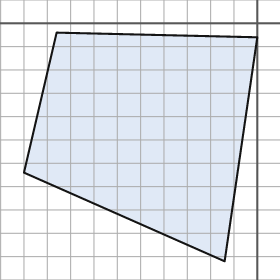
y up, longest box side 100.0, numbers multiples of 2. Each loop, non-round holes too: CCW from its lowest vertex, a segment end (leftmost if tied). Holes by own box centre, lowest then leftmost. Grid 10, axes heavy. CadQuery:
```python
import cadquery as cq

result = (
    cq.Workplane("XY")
    .moveTo(-14.0, -102.0)
    .lineTo(0.0, -6.0)
    .lineTo(-86.0, -4.0)
    .lineTo(-100.0, -64.0)
    .close()
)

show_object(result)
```